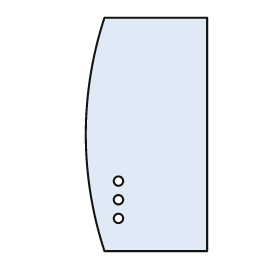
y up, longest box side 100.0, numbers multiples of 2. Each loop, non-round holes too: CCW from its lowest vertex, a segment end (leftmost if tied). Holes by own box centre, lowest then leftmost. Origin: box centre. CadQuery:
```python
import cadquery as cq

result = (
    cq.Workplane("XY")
    .moveTo(-18.0, -50.0)
    .lineTo(26.0, -50.0)
    .lineTo(26.0, 50.0)
    .lineTo(-18.0, 50.0)
    .threePointArc((-26.0, 0.0), (-18.0, -50.0))
    .close()
    .moveTo(-12.0, -36.0)
    .circle(2.0)
    .moveTo(-12.0, -28.0)
    .circle(2.0)
    .moveTo(-12.0, -20.0)
    .circle(2.0)
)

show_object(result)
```